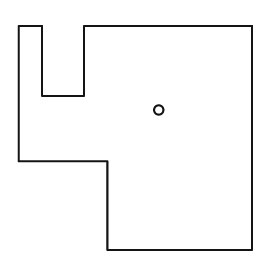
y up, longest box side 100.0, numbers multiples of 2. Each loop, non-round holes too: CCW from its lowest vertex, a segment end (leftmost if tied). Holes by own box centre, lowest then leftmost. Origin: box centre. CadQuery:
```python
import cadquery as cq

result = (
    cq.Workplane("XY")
    .moveTo(-12.0, -48.0)
    .lineTo(50.0, -48.0)
    .lineTo(50.0, 48.0)
    .lineTo(-22.0, 48.0)
    .lineTo(-22.0, 18.0)
    .lineTo(-40.0, 18.0)
    .lineTo(-40.0, 48.0)
    .lineTo(-50.0, 48.0)
    .lineTo(-50.0, -10.0)
    .lineTo(-12.0, -10.0)
    .close()
    .moveTo(10.0, 12.0)
    .circle(2.0)
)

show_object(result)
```